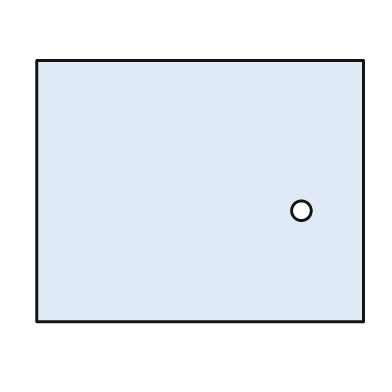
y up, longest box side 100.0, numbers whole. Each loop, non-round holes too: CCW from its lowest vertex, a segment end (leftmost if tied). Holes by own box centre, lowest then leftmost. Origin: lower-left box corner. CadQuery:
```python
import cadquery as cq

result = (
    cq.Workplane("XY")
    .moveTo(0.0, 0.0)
    .lineTo(100.0, 0.0)
    .lineTo(100.0, 80.0)
    .lineTo(0.0, 80.0)
    .close()
    .moveTo(81.0, 34.0)
    .circle(3.0)
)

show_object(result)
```